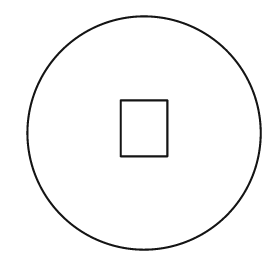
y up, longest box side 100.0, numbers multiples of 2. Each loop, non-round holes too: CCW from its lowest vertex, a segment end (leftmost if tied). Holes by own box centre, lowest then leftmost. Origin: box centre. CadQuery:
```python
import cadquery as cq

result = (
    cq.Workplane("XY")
    .moveTo(0.0, 0.0)
    .circle(50.0)
    .moveTo(-10.0, -10.0)
    .lineTo(10.0, -10.0)
    .lineTo(10.0, 14.0)
    .lineTo(-10.0, 14.0)
    .close()
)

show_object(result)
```